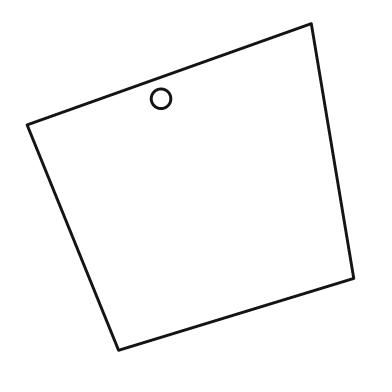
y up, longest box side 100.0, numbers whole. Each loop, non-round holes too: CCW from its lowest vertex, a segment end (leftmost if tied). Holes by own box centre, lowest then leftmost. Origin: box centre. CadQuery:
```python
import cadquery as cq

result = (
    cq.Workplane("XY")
    .moveTo(-22.0, -50.0)
    .lineTo(50.0, -28.0)
    .lineTo(37.0, 50.0)
    .lineTo(-50.0, 19.0)
    .close()
    .moveTo(-9.0, 27.0)
    .circle(3.0)
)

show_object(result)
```